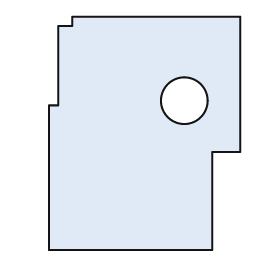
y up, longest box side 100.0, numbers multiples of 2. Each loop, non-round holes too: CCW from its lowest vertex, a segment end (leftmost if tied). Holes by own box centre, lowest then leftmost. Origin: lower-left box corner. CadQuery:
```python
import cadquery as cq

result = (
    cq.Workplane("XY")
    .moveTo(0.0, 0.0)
    .lineTo(70.0, 0.0)
    .lineTo(70.0, 42.0)
    .lineTo(82.0, 42.0)
    .lineTo(82.0, 100.0)
    .lineTo(10.0, 100.0)
    .lineTo(10.0, 96.0)
    .lineTo(4.0, 96.0)
    .lineTo(4.0, 62.0)
    .lineTo(0.0, 62.0)
    .close()
    .moveTo(58.0, 64.0)
    .circle(10.0)
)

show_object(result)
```